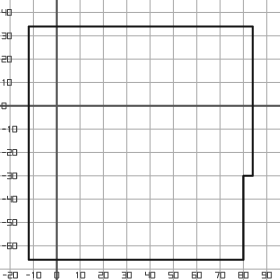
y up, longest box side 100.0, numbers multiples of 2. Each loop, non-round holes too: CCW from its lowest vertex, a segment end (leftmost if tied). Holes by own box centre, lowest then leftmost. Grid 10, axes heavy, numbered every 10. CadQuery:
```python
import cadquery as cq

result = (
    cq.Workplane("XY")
    .moveTo(-12.0, -66.0)
    .lineTo(80.0, -66.0)
    .lineTo(80.0, -30.0)
    .lineTo(84.0, -30.0)
    .lineTo(84.0, 34.0)
    .lineTo(-12.0, 34.0)
    .close()
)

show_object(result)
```